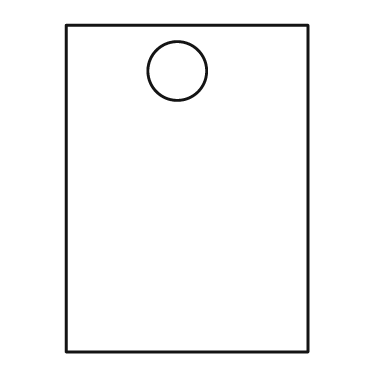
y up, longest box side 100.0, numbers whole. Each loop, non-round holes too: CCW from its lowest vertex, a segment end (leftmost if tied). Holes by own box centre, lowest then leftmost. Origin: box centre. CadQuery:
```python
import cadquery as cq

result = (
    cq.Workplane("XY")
    .moveTo(-37.0, -50.0)
    .lineTo(37.0, -50.0)
    .lineTo(37.0, 50.0)
    .lineTo(-37.0, 50.0)
    .close()
    .moveTo(-3.0, 36.0)
    .circle(9.0)
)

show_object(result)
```